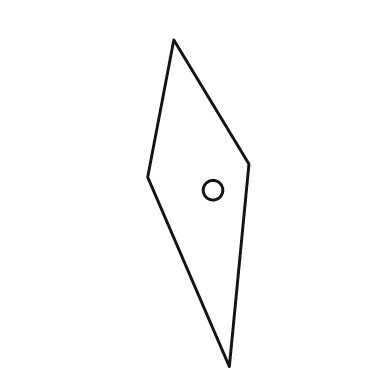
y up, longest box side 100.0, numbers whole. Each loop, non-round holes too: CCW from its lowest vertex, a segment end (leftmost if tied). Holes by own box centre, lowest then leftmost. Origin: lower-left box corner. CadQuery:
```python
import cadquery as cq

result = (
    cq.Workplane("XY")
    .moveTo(25.0, 0.0)
    .lineTo(31.0, 62.0)
    .lineTo(8.0, 100.0)
    .lineTo(0.0, 58.0)
    .close()
    .moveTo(20.0, 54.0)
    .circle(3.0)
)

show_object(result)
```